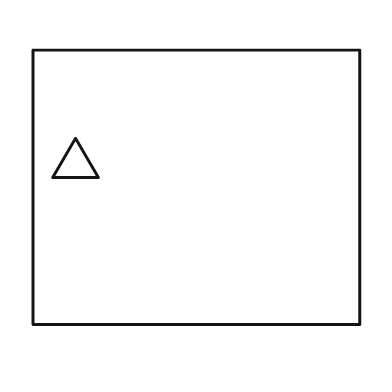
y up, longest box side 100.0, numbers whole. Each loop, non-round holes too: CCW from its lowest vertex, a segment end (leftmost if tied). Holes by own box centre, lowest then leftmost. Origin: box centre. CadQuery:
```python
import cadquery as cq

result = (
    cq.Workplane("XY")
    .moveTo(-50.0, -42.0)
    .lineTo(50.0, -42.0)
    .lineTo(50.0, 42.0)
    .lineTo(-50.0, 42.0)
    .close()
    .moveTo(-44.0, 3.0)
    .lineTo(-30.0, 3.0)
    .lineTo(-37.0, 15.0)
    .close()
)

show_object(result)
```